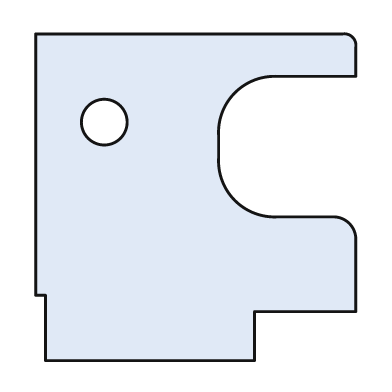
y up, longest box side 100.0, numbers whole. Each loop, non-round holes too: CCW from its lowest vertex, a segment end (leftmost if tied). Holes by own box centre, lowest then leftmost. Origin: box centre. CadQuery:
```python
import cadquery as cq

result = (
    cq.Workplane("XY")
    .moveTo(-46.0, -50.0)
    .lineTo(18.0, -50.0)
    .lineTo(18.0, -35.0)
    .lineTo(49.0, -35.0)
    .lineTo(49.0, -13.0)
    .threePointArc((47.0, -8.0), (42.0, -6.0))
    .lineTo(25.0, -6.0)
    .threePointArc((12.0, -1.0), (7.0, 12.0))
    .lineTo(7.0, 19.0)
    .threePointArc((12.0, 32.0), (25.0, 37.0))
    .lineTo(49.0, 37.0)
    .lineTo(49.0, 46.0)
    .threePointArc((48.0, 49.0), (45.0, 50.0))
    .lineTo(-49.0, 50.0)
    .lineTo(-49.0, -30.0)
    .lineTo(-46.0, -30.0)
    .close()
    .moveTo(-28.0, 23.0)
    .circle(7.0)
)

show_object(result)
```